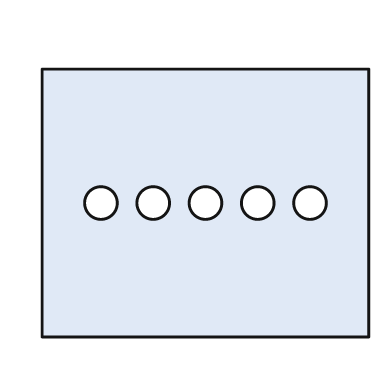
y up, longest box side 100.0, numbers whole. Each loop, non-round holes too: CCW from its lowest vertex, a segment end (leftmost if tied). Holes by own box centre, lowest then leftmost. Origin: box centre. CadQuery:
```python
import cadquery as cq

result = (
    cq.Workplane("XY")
    .moveTo(-50.0, -41.0)
    .lineTo(50.0, -41.0)
    .lineTo(50.0, 41.0)
    .lineTo(-50.0, 41.0)
    .close()
    .moveTo(-32.0, 0.0)
    .circle(5.0)
    .moveTo(-16.0, 0.0)
    .circle(5.0)
    .moveTo(0.0, 0.0)
    .circle(5.0)
    .moveTo(16.0, 0.0)
    .circle(5.0)
    .moveTo(32.0, 0.0)
    .circle(5.0)
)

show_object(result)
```